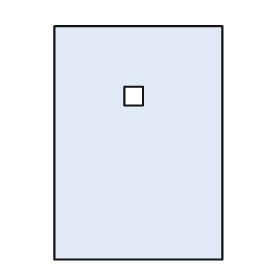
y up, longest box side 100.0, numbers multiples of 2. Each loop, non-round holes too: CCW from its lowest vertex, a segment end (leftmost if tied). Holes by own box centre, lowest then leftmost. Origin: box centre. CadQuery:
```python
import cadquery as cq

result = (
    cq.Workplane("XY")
    .moveTo(-36.0, -50.0)
    .lineTo(36.0, -50.0)
    .lineTo(36.0, 50.0)
    .lineTo(-36.0, 50.0)
    .close()
    .moveTo(-6.0, 16.0)
    .lineTo(2.0, 16.0)
    .lineTo(2.0, 24.0)
    .lineTo(-6.0, 24.0)
    .close()
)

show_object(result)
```